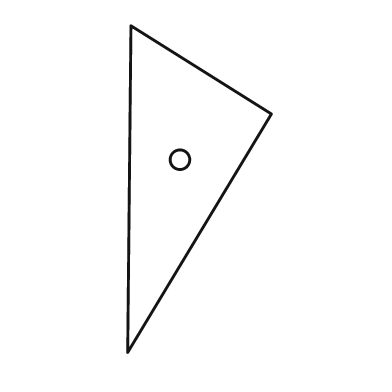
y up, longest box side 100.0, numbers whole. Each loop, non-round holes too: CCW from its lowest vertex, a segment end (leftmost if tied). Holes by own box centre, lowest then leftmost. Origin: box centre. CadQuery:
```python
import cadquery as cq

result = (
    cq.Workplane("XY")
    .moveTo(-22.0, -50.0)
    .lineTo(22.0, 23.0)
    .lineTo(-21.0, 50.0)
    .close()
    .moveTo(-6.0, 9.0)
    .circle(3.0)
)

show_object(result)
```